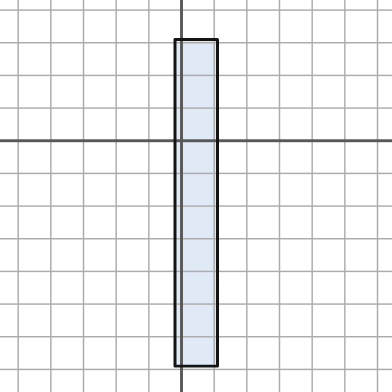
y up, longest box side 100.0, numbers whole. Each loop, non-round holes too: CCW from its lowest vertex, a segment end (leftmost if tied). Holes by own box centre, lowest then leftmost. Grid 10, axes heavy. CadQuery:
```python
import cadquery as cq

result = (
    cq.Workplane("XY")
    .moveTo(-2.0, -69.0)
    .lineTo(11.0, -69.0)
    .lineTo(11.0, 31.0)
    .lineTo(-2.0, 31.0)
    .close()
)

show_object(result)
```